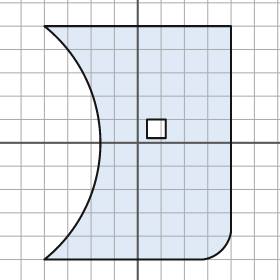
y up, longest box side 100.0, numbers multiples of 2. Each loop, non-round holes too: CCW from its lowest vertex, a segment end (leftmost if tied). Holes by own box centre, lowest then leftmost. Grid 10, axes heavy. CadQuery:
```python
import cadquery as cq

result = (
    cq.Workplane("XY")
    .moveTo(-40.0, -50.0)
    .lineTo(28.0, -50.0)
    .threePointArc((36.0, -46.0), (40.0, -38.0))
    .lineTo(40.0, 50.0)
    .lineTo(-40.0, 50.0)
    .threePointArc((-16.0, 0.0), (-40.0, -50.0))
    .close()
    .moveTo(4.0, 2.0)
    .lineTo(12.0, 2.0)
    .lineTo(12.0, 10.0)
    .lineTo(4.0, 10.0)
    .close()
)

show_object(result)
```